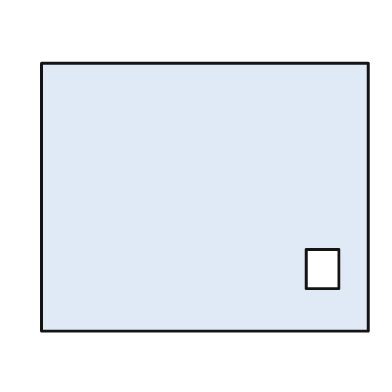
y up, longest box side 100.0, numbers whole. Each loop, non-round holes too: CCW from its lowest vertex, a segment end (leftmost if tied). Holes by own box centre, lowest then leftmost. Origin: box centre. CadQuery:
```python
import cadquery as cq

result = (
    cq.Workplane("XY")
    .moveTo(-50.0, -41.0)
    .lineTo(50.0, -41.0)
    .lineTo(50.0, 41.0)
    .lineTo(-50.0, 41.0)
    .close()
    .moveTo(31.0, -28.0)
    .lineTo(41.0, -28.0)
    .lineTo(41.0, -16.0)
    .lineTo(31.0, -16.0)
    .close()
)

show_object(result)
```